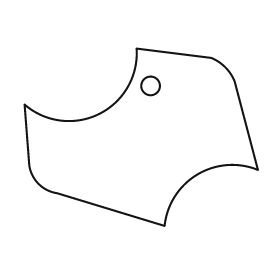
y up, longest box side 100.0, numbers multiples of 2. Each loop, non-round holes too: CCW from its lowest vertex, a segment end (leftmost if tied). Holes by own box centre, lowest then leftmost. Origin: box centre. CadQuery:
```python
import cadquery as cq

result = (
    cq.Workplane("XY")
    .moveTo(10.0, -38.0)
    .threePointArc((24.0, -16.0), (50.0, -14.0))
    .lineTo(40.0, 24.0)
    .threePointArc((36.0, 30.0), (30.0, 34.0))
    .lineTo(-2.0, 38.0)
    .threePointArc((-18.0, 10.0), (-50.0, 14.0))
    .lineTo(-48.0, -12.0)
    .threePointArc((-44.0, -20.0), (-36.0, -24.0))
    .close()
    .moveTo(4.0, 22.0)
    .circle(4.0)
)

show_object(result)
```